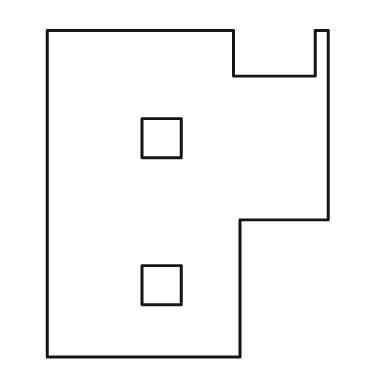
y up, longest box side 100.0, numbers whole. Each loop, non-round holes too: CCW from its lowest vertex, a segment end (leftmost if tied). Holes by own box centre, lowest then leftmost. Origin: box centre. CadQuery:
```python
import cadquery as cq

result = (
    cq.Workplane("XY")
    .moveTo(-43.0, -50.0)
    .lineTo(16.0, -50.0)
    .lineTo(16.0, -8.0)
    .lineTo(43.0, -8.0)
    .lineTo(43.0, 50.0)
    .lineTo(39.0, 50.0)
    .lineTo(39.0, 36.0)
    .lineTo(14.0, 36.0)
    .lineTo(14.0, 50.0)
    .lineTo(-43.0, 50.0)
    .close()
    .moveTo(-14.0, -34.0)
    .lineTo(-2.0, -34.0)
    .lineTo(-2.0, -22.0)
    .lineTo(-14.0, -22.0)
    .close()
    .moveTo(-14.0, 11.0)
    .lineTo(-2.0, 11.0)
    .lineTo(-2.0, 23.0)
    .lineTo(-14.0, 23.0)
    .close()
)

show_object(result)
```